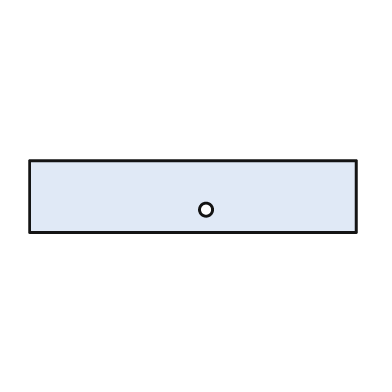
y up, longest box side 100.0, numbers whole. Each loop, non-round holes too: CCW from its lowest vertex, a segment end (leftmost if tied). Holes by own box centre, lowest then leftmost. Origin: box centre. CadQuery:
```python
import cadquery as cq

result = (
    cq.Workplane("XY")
    .moveTo(-50.0, -11.0)
    .lineTo(50.0, -11.0)
    .lineTo(50.0, 11.0)
    .lineTo(-50.0, 11.0)
    .close()
    .moveTo(4.0, -4.0)
    .circle(2.0)
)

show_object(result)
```